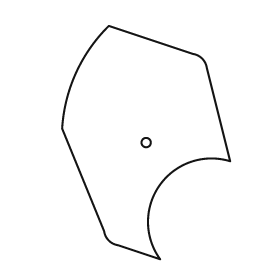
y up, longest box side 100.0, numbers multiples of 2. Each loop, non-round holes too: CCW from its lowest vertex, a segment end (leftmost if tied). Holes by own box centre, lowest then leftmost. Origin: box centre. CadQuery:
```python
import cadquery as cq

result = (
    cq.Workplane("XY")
    .moveTo(6.0, -50.0)
    .threePointArc((6.0, -18.0), (36.0, -8.0))
    .lineTo(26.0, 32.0)
    .threePointArc((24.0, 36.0), (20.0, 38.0))
    .lineTo(-16.0, 50.0)
    .threePointArc((-30.0, 30.0), (-36.0, 6.0))
    .lineTo(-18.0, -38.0)
    .threePointArc((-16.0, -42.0), (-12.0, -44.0))
    .close()
    .moveTo(0.0, 0.0)
    .circle(2.0)
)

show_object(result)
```